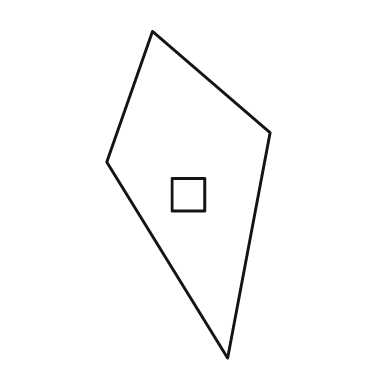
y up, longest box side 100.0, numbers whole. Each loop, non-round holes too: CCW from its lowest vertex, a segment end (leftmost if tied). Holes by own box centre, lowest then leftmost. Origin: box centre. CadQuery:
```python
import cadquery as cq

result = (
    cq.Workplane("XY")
    .moveTo(12.0, -50.0)
    .lineTo(25.0, 19.0)
    .lineTo(-11.0, 50.0)
    .lineTo(-25.0, 10.0)
    .close()
    .moveTo(-5.0, -5.0)
    .lineTo(5.0, -5.0)
    .lineTo(5.0, 5.0)
    .lineTo(-5.0, 5.0)
    .close()
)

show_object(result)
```